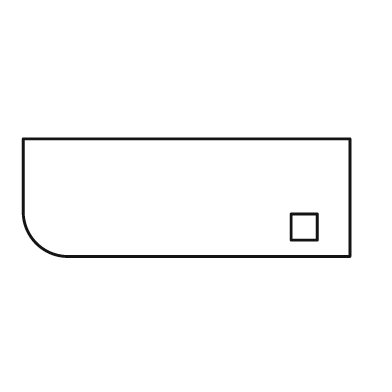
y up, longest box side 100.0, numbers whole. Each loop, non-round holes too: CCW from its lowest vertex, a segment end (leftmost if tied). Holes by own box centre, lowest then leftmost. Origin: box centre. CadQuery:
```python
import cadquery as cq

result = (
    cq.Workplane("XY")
    .moveTo(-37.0, -18.0)
    .lineTo(50.0, -18.0)
    .lineTo(50.0, 18.0)
    .lineTo(-50.0, 18.0)
    .lineTo(-50.0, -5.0)
    .threePointArc((-46.0, -14.0), (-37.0, -18.0))
    .close()
    .moveTo(32.0, -13.0)
    .lineTo(40.0, -13.0)
    .lineTo(40.0, -5.0)
    .lineTo(32.0, -5.0)
    .close()
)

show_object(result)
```